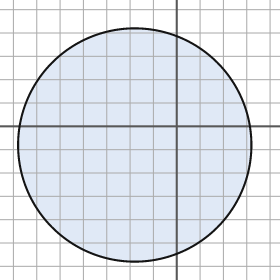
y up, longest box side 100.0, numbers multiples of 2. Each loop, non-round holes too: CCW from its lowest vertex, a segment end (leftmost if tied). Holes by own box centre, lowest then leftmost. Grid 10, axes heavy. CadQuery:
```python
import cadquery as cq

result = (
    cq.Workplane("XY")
    .moveTo(-18.0, -8.0)
    .circle(50.0)
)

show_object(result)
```